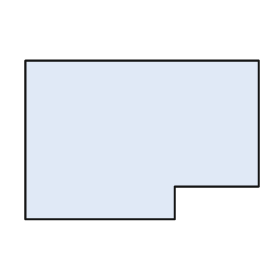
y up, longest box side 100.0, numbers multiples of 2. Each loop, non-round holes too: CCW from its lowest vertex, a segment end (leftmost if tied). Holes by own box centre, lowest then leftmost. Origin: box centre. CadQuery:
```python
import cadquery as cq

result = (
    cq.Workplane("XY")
    .moveTo(-50.0, -34.0)
    .lineTo(14.0, -34.0)
    .lineTo(14.0, -20.0)
    .lineTo(50.0, -20.0)
    .lineTo(50.0, 34.0)
    .lineTo(-50.0, 34.0)
    .close()
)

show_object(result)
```